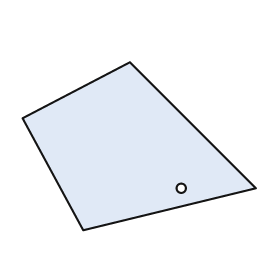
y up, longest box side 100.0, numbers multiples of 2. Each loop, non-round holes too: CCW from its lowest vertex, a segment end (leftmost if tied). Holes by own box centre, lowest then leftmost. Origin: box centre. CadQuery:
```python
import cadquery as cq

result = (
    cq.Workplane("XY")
    .moveTo(-24.0, -36.0)
    .lineTo(50.0, -18.0)
    .lineTo(-4.0, 36.0)
    .lineTo(-50.0, 12.0)
    .close()
    .moveTo(18.0, -18.0)
    .circle(2.0)
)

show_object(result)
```